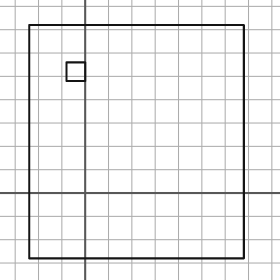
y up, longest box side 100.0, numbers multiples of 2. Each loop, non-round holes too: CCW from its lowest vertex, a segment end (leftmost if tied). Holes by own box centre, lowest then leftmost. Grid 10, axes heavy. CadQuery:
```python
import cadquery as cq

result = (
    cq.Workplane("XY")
    .moveTo(-24.0, -28.0)
    .lineTo(68.0, -28.0)
    .lineTo(68.0, 72.0)
    .lineTo(-24.0, 72.0)
    .close()
    .moveTo(-8.0, 48.0)
    .lineTo(0.0, 48.0)
    .lineTo(0.0, 56.0)
    .lineTo(-8.0, 56.0)
    .close()
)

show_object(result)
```